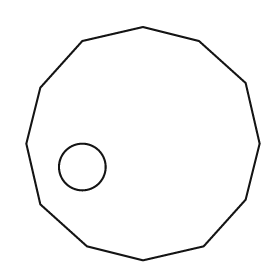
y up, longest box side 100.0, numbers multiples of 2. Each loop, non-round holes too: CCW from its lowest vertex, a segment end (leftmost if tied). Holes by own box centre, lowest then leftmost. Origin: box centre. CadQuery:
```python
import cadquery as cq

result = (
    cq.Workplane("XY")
    .moveTo(0.0, -50.0)
    .lineTo(26.0, -44.0)
    .lineTo(44.0, -24.0)
    .lineTo(50.0, 0.0)
    .lineTo(44.0, 26.0)
    .lineTo(24.0, 44.0)
    .lineTo(0.0, 50.0)
    .lineTo(-26.0, 44.0)
    .lineTo(-44.0, 24.0)
    .lineTo(-50.0, 0.0)
    .lineTo(-44.0, -26.0)
    .lineTo(-24.0, -44.0)
    .close()
    .moveTo(-26.0, -10.0)
    .circle(10.0)
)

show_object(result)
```